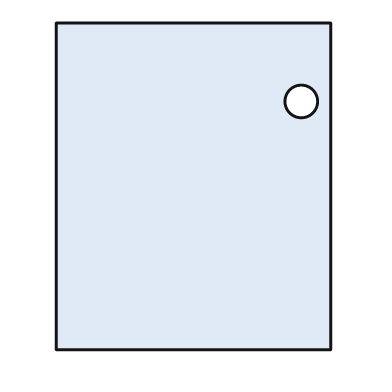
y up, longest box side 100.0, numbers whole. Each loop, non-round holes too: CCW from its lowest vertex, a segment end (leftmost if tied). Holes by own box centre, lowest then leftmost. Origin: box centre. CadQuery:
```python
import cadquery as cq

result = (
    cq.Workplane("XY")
    .moveTo(-42.0, -50.0)
    .lineTo(42.0, -50.0)
    .lineTo(42.0, 50.0)
    .lineTo(-42.0, 50.0)
    .close()
    .moveTo(33.0, 26.0)
    .circle(5.0)
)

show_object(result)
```